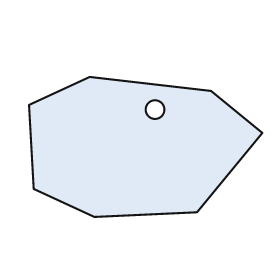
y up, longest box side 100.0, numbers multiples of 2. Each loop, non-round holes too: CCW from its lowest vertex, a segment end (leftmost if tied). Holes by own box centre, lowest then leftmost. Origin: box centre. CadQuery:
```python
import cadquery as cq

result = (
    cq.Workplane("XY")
    .moveTo(-22.0, -30.0)
    .lineTo(22.0, -28.0)
    .lineTo(50.0, 6.0)
    .lineTo(28.0, 24.0)
    .lineTo(-24.0, 30.0)
    .lineTo(-50.0, 18.0)
    .lineTo(-48.0, -18.0)
    .close()
    .moveTo(4.0, 16.0)
    .circle(4.0)
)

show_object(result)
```